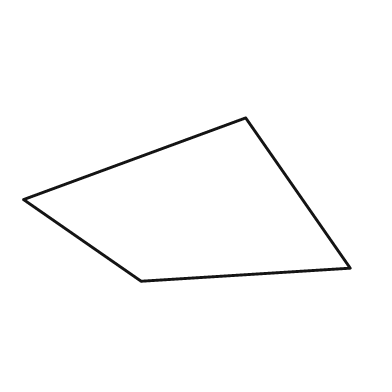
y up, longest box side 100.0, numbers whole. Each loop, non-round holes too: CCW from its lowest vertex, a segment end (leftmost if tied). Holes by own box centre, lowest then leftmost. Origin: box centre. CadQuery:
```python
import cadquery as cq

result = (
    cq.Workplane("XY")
    .moveTo(-14.0, -25.0)
    .lineTo(50.0, -21.0)
    .lineTo(18.0, 25.0)
    .lineTo(-50.0, 0.0)
    .close()
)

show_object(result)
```